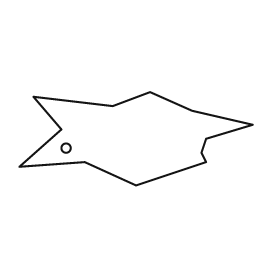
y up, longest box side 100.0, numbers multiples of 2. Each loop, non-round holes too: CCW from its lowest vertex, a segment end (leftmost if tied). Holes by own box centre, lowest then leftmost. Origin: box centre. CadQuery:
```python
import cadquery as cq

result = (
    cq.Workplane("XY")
    .moveTo(0.0, -20.0)
    .lineTo(30.0, -10.0)
    .lineTo(28.0, -6.0)
    .lineTo(30.0, 0.0)
    .lineTo(50.0, 6.0)
    .lineTo(24.0, 12.0)
    .lineTo(6.0, 20.0)
    .lineTo(-10.0, 14.0)
    .lineTo(-44.0, 18.0)
    .lineTo(-32.0, 4.0)
    .lineTo(-50.0, -12.0)
    .lineTo(-22.0, -10.0)
    .close()
    .moveTo(-30.0, -4.0)
    .circle(2.0)
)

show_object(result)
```